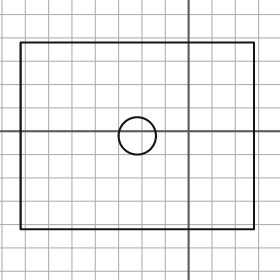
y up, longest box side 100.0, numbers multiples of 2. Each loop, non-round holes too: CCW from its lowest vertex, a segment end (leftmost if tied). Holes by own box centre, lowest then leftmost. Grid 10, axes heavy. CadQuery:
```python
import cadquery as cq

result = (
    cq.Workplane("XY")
    .moveTo(-72.0, -42.0)
    .lineTo(28.0, -42.0)
    .lineTo(28.0, 38.0)
    .lineTo(-72.0, 38.0)
    .close()
    .moveTo(-22.0, -2.0)
    .circle(8.0)
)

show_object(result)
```